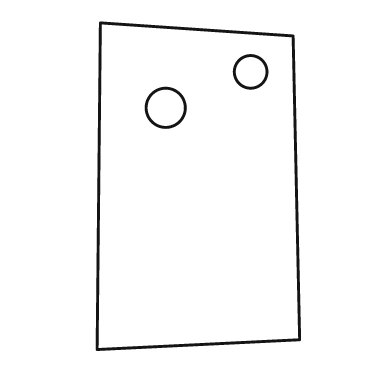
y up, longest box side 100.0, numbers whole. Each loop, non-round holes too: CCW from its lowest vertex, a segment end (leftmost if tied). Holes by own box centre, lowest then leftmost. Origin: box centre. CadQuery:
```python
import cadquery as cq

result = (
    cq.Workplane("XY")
    .moveTo(-31.0, -50.0)
    .lineTo(31.0, -47.0)
    .lineTo(29.0, 46.0)
    .lineTo(-30.0, 50.0)
    .close()
    .moveTo(-10.0, 24.0)
    .circle(6.0)
    .moveTo(16.0, 35.0)
    .circle(5.0)
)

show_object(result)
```